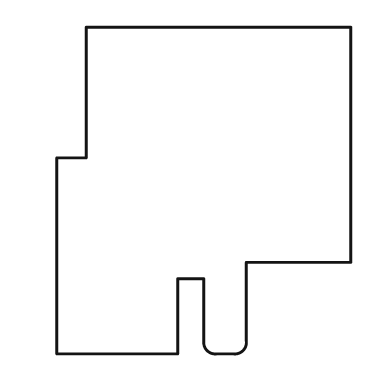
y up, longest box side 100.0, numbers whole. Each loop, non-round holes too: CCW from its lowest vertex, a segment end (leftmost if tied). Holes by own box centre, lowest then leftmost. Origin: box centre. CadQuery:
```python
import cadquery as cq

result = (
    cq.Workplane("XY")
    .moveTo(-45.0, -50.0)
    .lineTo(-8.0, -50.0)
    .lineTo(-8.0, -27.0)
    .lineTo(0.0, -27.0)
    .lineTo(0.0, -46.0)
    .threePointArc((1.0, -49.0), (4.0, -50.0))
    .lineTo(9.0, -50.0)
    .threePointArc((12.0, -49.0), (13.0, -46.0))
    .lineTo(13.0, -22.0)
    .lineTo(45.0, -22.0)
    .lineTo(45.0, 50.0)
    .lineTo(-36.0, 50.0)
    .lineTo(-36.0, 10.0)
    .lineTo(-45.0, 10.0)
    .close()
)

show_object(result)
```